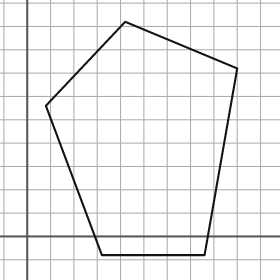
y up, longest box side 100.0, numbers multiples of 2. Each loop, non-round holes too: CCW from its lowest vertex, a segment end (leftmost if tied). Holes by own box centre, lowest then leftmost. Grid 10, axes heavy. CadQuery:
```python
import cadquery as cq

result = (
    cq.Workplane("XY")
    .moveTo(32.0, -8.0)
    .lineTo(76.0, -8.0)
    .lineTo(90.0, 72.0)
    .lineTo(42.0, 92.0)
    .lineTo(8.0, 56.0)
    .close()
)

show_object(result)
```